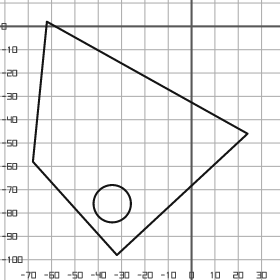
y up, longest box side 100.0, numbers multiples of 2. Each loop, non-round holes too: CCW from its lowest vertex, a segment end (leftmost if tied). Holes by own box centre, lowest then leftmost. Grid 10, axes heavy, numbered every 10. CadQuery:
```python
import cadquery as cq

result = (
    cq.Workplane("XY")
    .moveTo(-32.0, -98.0)
    .lineTo(24.0, -46.0)
    .lineTo(-62.0, 2.0)
    .lineTo(-68.0, -58.0)
    .close()
    .moveTo(-34.0, -76.0)
    .circle(8.0)
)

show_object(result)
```